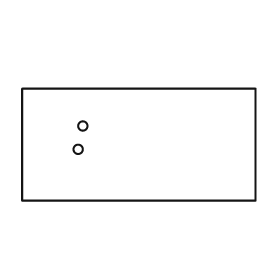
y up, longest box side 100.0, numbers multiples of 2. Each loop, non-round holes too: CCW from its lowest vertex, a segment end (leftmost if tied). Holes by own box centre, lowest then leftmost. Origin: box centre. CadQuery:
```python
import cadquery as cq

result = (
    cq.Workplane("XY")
    .moveTo(-50.0, -24.0)
    .lineTo(50.0, -24.0)
    .lineTo(50.0, 24.0)
    .lineTo(-50.0, 24.0)
    .close()
    .moveTo(-26.0, -2.0)
    .circle(2.0)
    .moveTo(-24.0, 8.0)
    .circle(2.0)
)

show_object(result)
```